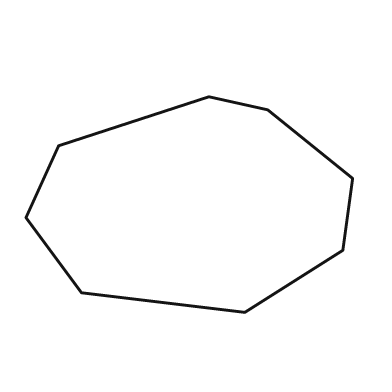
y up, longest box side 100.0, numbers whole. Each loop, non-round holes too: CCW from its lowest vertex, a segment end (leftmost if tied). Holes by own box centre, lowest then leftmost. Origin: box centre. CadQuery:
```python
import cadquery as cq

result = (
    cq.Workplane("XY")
    .moveTo(17.0, -33.0)
    .lineTo(47.0, -14.0)
    .lineTo(50.0, 8.0)
    .lineTo(24.0, 29.0)
    .lineTo(6.0, 33.0)
    .lineTo(-40.0, 18.0)
    .lineTo(-50.0, -4.0)
    .lineTo(-33.0, -27.0)
    .close()
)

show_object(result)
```